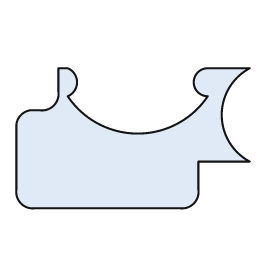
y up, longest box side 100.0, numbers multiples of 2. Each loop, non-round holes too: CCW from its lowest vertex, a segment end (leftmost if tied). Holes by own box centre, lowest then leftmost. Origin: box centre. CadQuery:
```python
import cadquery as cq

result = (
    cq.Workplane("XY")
    .moveTo(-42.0, -30.0)
    .lineTo(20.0, -30.0)
    .threePointArc((26.0, -28.0), (28.0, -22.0))
    .lineTo(28.0, -10.0)
    .lineTo(50.0, -10.0)
    .threePointArc((38.0, 10.0), (50.0, 30.0))
    .lineTo(32.0, 30.0)
    .threePointArc((26.0, 24.0), (32.0, 18.0))
    .threePointArc((2.0, 2.0), (-28.0, 18.0))
    .threePointArc((-24.0, 24.0), (-28.0, 30.0))
    .lineTo(-32.0, 30.0)
    .lineTo(-32.0, 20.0)
    .threePointArc((-34.0, 14.0), (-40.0, 12.0))
    .lineTo(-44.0, 12.0)
    .threePointArc((-48.0, 10.0), (-50.0, 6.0))
    .lineTo(-50.0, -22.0)
    .threePointArc((-48.0, -28.0), (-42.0, -30.0))
    .close()
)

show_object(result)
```